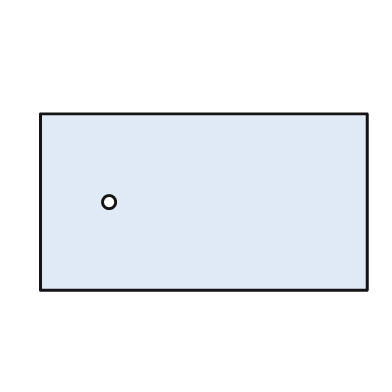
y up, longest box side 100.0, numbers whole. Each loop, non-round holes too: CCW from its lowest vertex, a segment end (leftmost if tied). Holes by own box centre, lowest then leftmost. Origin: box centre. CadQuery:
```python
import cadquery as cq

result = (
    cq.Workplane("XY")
    .moveTo(-50.0, -27.0)
    .lineTo(50.0, -27.0)
    .lineTo(50.0, 27.0)
    .lineTo(-50.0, 27.0)
    .close()
    .moveTo(-29.0, 0.0)
    .circle(2.0)
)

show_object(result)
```